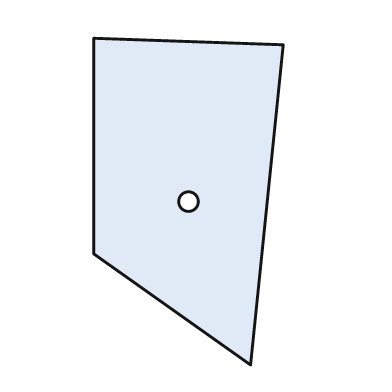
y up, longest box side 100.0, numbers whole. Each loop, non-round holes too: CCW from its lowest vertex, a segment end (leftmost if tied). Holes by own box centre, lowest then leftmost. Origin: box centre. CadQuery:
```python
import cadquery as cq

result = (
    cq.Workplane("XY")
    .moveTo(19.0, -50.0)
    .lineTo(29.0, 48.0)
    .lineTo(-29.0, 50.0)
    .lineTo(-29.0, -16.0)
    .close()
    .moveTo(0.0, 0.0)
    .circle(3.0)
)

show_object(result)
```